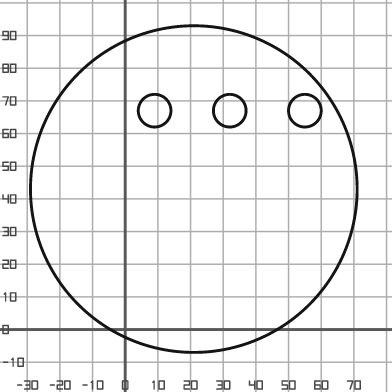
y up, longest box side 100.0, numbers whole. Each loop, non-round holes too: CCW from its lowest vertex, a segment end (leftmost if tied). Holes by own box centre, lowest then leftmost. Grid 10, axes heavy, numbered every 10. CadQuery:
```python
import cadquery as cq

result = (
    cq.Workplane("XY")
    .moveTo(21.0, 43.0)
    .circle(50.0)
    .moveTo(9.0, 67.0)
    .circle(5.0)
    .moveTo(32.0, 67.0)
    .circle(5.0)
    .moveTo(55.0, 67.0)
    .circle(5.0)
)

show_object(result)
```